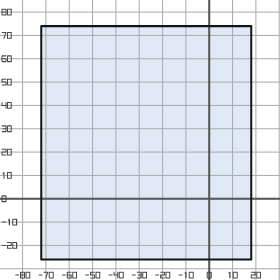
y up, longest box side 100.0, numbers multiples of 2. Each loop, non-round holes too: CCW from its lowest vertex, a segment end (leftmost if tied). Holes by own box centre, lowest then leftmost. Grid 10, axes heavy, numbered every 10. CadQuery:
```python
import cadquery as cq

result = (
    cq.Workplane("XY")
    .moveTo(-72.0, -26.0)
    .lineTo(18.0, -26.0)
    .lineTo(18.0, 74.0)
    .lineTo(-72.0, 74.0)
    .close()
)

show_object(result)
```